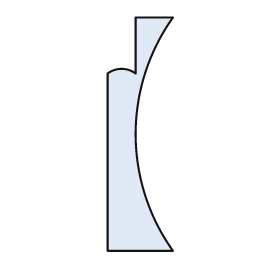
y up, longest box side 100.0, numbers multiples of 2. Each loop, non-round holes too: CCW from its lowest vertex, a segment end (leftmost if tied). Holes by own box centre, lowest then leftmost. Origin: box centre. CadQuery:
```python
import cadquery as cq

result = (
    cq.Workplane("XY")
    .moveTo(-14.0, -50.0)
    .lineTo(14.0, -50.0)
    .threePointArc((-2.0, 0.0), (14.0, 50.0))
    .lineTo(-2.0, 50.0)
    .lineTo(-2.0, 26.0)
    .threePointArc((-8.0, 28.0), (-14.0, 26.0))
    .close()
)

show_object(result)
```